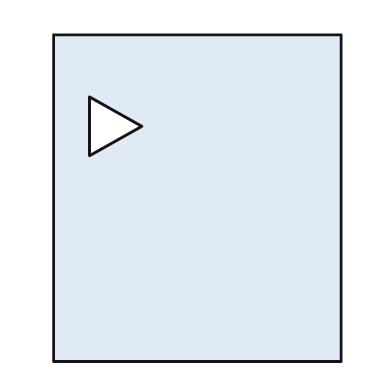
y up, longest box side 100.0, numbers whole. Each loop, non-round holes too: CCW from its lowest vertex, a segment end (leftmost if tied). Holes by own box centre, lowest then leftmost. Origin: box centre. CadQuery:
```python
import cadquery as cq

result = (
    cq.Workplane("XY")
    .moveTo(-44.0, -50.0)
    .lineTo(44.0, -50.0)
    .lineTo(44.0, 50.0)
    .lineTo(-44.0, 50.0)
    .close()
    .moveTo(-33.0, 13.0)
    .lineTo(-17.0, 22.0)
    .lineTo(-33.0, 31.0)
    .close()
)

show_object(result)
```